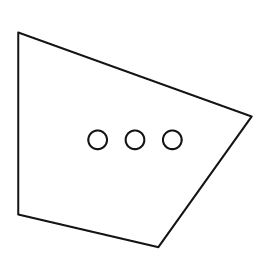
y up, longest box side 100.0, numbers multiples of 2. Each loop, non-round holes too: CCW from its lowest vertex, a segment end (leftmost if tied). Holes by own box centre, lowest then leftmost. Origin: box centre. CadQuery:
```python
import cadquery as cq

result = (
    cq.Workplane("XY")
    .moveTo(10.0, -46.0)
    .lineTo(50.0, 10.0)
    .lineTo(-50.0, 46.0)
    .lineTo(-50.0, -32.0)
    .close()
    .moveTo(-16.0, 0.0)
    .circle(4.0)
    .moveTo(0.0, 0.0)
    .circle(4.0)
    .moveTo(16.0, 0.0)
    .circle(4.0)
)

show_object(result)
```